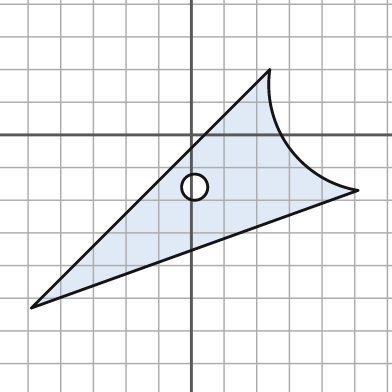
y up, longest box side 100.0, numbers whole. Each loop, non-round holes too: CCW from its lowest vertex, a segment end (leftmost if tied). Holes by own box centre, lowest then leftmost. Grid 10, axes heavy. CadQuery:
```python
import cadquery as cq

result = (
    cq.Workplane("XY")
    .moveTo(-49.0, -53.0)
    .lineTo(51.0, -17.0)
    .threePointArc((30.0, -4.0), (24.0, 20.0))
    .close()
    .moveTo(1.0, -16.0)
    .circle(4.0)
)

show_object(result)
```